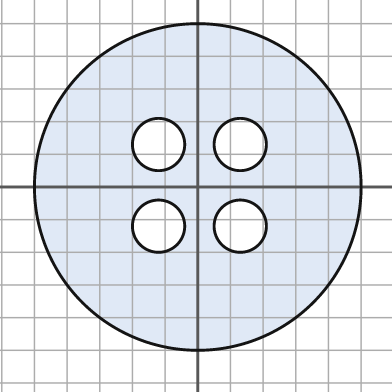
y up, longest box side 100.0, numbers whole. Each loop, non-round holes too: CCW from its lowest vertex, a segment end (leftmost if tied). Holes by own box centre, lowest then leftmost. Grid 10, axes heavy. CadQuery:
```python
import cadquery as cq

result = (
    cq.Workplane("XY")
    .moveTo(0.0, 0.0)
    .circle(50.0)
    .moveTo(-12.0, -12.0)
    .circle(8.0)
    .moveTo(13.0, -12.0)
    .circle(8.0)
    .moveTo(-12.0, 13.0)
    .circle(8.0)
    .moveTo(13.0, 13.0)
    .circle(8.0)
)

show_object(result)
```